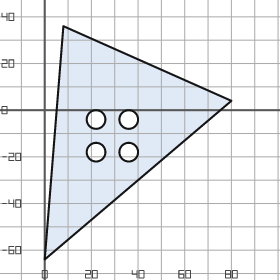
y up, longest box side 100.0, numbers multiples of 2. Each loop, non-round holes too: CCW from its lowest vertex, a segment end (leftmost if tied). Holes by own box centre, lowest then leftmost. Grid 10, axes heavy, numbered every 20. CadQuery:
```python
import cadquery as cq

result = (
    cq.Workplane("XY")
    .moveTo(0.0, -64.0)
    .lineTo(80.0, 4.0)
    .lineTo(8.0, 36.0)
    .close()
    .moveTo(22.0, -18.0)
    .circle(4.0)
    .moveTo(36.0, -18.0)
    .circle(4.0)
    .moveTo(22.0, -4.0)
    .circle(4.0)
    .moveTo(36.0, -4.0)
    .circle(4.0)
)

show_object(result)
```